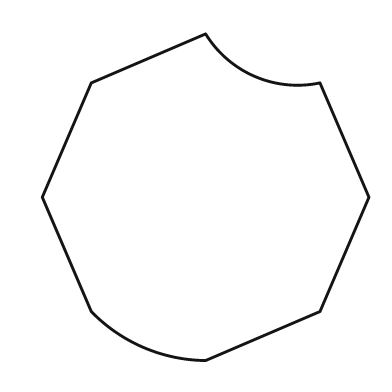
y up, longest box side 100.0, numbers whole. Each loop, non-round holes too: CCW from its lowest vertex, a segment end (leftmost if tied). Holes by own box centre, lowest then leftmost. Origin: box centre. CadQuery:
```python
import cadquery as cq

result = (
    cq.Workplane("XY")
    .moveTo(0.0, -50.0)
    .lineTo(35.0, -35.0)
    .lineTo(50.0, 0.0)
    .lineTo(35.0, 35.0)
    .threePointArc((15.0, 37.0), (0.0, 50.0))
    .lineTo(-35.0, 35.0)
    .lineTo(-50.0, 0.0)
    .lineTo(-35.0, -35.0)
    .threePointArc((-19.0, -46.0), (0.0, -50.0))
    .close()
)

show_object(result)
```